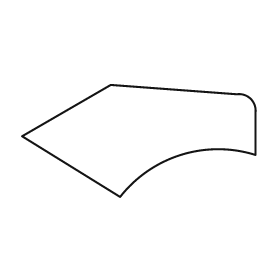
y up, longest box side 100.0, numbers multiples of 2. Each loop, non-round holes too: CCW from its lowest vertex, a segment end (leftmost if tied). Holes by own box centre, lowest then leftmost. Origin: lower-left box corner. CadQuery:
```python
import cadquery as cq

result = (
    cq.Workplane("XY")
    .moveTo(42.0, 0.0)
    .threePointArc((68.0, 18.0), (100.0, 18.0))
    .lineTo(100.0, 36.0)
    .threePointArc((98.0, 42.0), (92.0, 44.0))
    .lineTo(38.0, 48.0)
    .lineTo(0.0, 26.0)
    .close()
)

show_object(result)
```